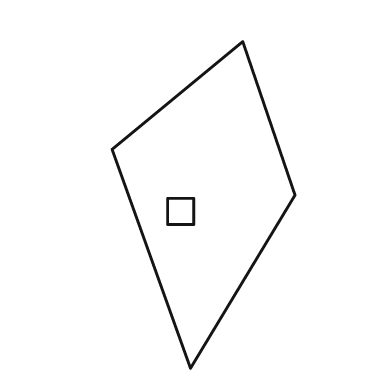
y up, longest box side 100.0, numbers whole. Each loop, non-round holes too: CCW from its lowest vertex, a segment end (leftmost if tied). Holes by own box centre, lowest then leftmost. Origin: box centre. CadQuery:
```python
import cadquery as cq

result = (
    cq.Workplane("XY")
    .moveTo(-4.0, -50.0)
    .lineTo(28.0, 3.0)
    .lineTo(12.0, 50.0)
    .lineTo(-28.0, 17.0)
    .close()
    .moveTo(-11.0, -6.0)
    .lineTo(-3.0, -6.0)
    .lineTo(-3.0, 2.0)
    .lineTo(-11.0, 2.0)
    .close()
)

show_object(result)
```